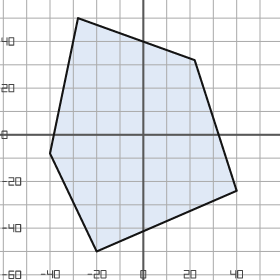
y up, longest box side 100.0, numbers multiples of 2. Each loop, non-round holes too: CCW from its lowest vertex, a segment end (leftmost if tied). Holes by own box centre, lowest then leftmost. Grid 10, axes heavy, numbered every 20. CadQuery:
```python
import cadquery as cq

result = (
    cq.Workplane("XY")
    .moveTo(-20.0, -50.0)
    .lineTo(40.0, -24.0)
    .lineTo(22.0, 32.0)
    .lineTo(-28.0, 50.0)
    .lineTo(-40.0, -8.0)
    .close()
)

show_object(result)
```